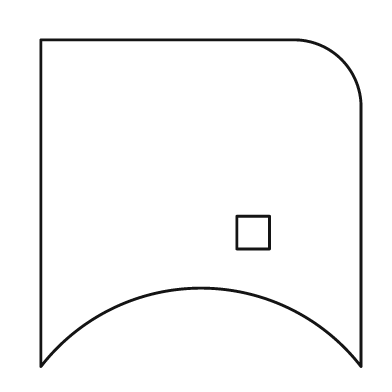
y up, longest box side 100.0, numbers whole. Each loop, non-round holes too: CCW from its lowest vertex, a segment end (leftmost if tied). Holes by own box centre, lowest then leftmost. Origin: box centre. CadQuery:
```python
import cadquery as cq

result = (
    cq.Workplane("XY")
    .moveTo(-49.0, -50.0)
    .threePointArc((0.0, -26.0), (49.0, -50.0))
    .lineTo(49.0, 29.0)
    .threePointArc((43.0, 44.0), (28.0, 50.0))
    .lineTo(-49.0, 50.0)
    .close()
    .moveTo(11.0, -14.0)
    .lineTo(21.0, -14.0)
    .lineTo(21.0, -4.0)
    .lineTo(11.0, -4.0)
    .close()
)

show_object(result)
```